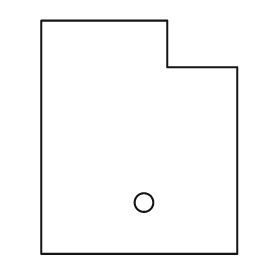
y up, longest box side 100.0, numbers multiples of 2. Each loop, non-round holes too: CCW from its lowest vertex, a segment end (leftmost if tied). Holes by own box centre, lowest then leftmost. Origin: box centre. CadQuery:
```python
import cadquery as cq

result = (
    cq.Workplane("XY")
    .moveTo(-42.0, -50.0)
    .lineTo(42.0, -50.0)
    .lineTo(42.0, 30.0)
    .lineTo(12.0, 30.0)
    .lineTo(12.0, 50.0)
    .lineTo(-42.0, 50.0)
    .close()
    .moveTo(2.0, -28.0)
    .circle(4.0)
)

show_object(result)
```